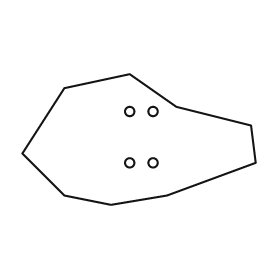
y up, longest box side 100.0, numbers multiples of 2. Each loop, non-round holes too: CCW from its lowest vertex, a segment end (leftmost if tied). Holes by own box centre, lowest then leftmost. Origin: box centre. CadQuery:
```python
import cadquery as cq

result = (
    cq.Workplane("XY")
    .moveTo(-12.0, -28.0)
    .lineTo(12.0, -24.0)
    .lineTo(50.0, -10.0)
    .lineTo(48.0, 6.0)
    .lineTo(16.0, 14.0)
    .lineTo(-4.0, 28.0)
    .lineTo(-32.0, 22.0)
    .lineTo(-50.0, -6.0)
    .lineTo(-32.0, -24.0)
    .close()
    .moveTo(-4.0, -10.0)
    .circle(2.0)
    .moveTo(6.0, -10.0)
    .circle(2.0)
    .moveTo(-4.0, 12.0)
    .circle(2.0)
    .moveTo(6.0, 12.0)
    .circle(2.0)
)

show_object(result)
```